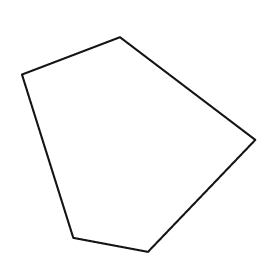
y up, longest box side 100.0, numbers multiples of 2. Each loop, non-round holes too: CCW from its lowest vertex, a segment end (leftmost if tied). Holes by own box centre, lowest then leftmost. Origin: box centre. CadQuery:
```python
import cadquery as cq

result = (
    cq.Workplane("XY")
    .moveTo(4.0, -46.0)
    .lineTo(50.0, 2.0)
    .lineTo(-8.0, 46.0)
    .lineTo(-50.0, 30.0)
    .lineTo(-28.0, -40.0)
    .close()
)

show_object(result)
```